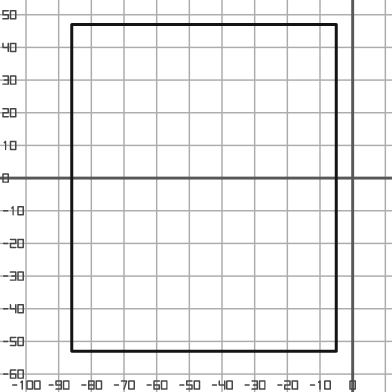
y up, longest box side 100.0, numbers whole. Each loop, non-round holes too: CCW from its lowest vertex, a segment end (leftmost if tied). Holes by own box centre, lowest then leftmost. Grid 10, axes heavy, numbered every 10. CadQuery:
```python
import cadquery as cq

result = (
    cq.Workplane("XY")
    .moveTo(-86.0, -53.0)
    .lineTo(-5.0, -53.0)
    .lineTo(-5.0, 47.0)
    .lineTo(-86.0, 47.0)
    .close()
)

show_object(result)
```